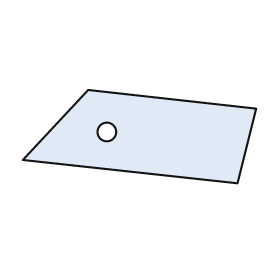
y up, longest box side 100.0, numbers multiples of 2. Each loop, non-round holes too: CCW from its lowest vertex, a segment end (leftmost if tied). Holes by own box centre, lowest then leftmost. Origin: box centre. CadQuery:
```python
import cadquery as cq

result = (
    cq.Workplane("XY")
    .moveTo(42.0, -20.0)
    .lineTo(50.0, 12.0)
    .lineTo(-22.0, 20.0)
    .lineTo(-50.0, -10.0)
    .close()
    .moveTo(-14.0, 2.0)
    .circle(4.0)
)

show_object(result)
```